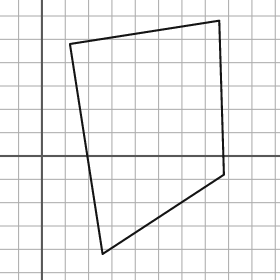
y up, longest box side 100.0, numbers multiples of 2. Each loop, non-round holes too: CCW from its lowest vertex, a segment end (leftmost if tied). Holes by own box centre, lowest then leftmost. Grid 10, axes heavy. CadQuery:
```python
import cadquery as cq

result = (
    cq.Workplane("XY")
    .moveTo(26.0, -42.0)
    .lineTo(78.0, -8.0)
    .lineTo(76.0, 58.0)
    .lineTo(12.0, 48.0)
    .close()
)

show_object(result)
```